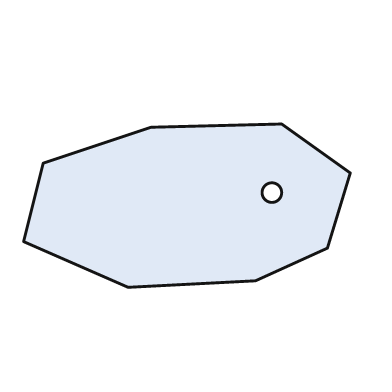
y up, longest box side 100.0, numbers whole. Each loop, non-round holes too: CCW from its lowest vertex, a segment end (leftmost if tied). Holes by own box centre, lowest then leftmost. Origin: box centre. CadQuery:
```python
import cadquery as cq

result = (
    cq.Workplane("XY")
    .moveTo(-18.0, -25.0)
    .lineTo(21.0, -23.0)
    .lineTo(43.0, -13.0)
    .lineTo(50.0, 10.0)
    .lineTo(29.0, 25.0)
    .lineTo(-11.0, 24.0)
    .lineTo(-44.0, 13.0)
    .lineTo(-50.0, -11.0)
    .close()
    .moveTo(26.0, 4.0)
    .circle(3.0)
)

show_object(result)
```